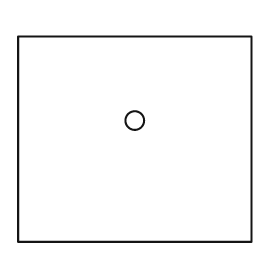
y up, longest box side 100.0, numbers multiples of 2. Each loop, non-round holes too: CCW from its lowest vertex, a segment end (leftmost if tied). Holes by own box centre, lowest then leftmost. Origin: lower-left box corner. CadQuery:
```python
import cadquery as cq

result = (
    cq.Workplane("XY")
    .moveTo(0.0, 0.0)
    .lineTo(100.0, 0.0)
    .lineTo(100.0, 88.0)
    .lineTo(0.0, 88.0)
    .close()
    .moveTo(50.0, 52.0)
    .circle(4.0)
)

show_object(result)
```